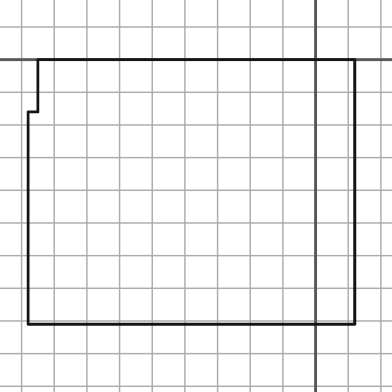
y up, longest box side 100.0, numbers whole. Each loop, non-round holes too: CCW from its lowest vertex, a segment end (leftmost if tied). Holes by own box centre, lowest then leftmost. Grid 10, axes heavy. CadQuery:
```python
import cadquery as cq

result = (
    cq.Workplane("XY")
    .moveTo(-88.0, -81.0)
    .lineTo(12.0, -81.0)
    .lineTo(12.0, 0.0)
    .lineTo(-85.0, 0.0)
    .lineTo(-85.0, -16.0)
    .lineTo(-88.0, -16.0)
    .close()
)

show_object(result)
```